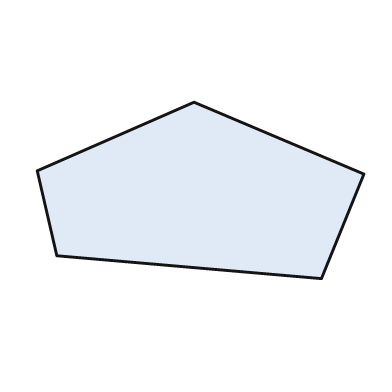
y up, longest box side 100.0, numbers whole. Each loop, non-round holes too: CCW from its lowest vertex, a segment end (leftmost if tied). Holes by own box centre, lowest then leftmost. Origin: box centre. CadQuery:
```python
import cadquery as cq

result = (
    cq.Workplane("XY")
    .moveTo(37.0, -27.0)
    .lineTo(50.0, 5.0)
    .lineTo(-2.0, 27.0)
    .lineTo(-50.0, 6.0)
    .lineTo(-44.0, -20.0)
    .close()
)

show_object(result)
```